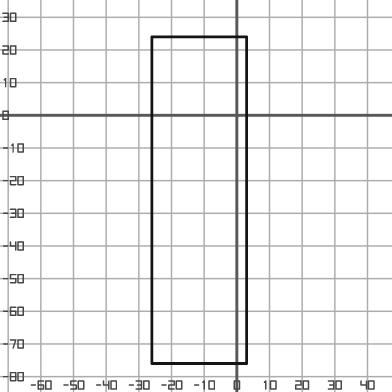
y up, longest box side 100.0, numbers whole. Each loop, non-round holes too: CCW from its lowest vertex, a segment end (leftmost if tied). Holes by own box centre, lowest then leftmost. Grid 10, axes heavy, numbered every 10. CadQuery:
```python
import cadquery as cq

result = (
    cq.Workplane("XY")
    .moveTo(-26.0, -76.0)
    .lineTo(3.0, -76.0)
    .lineTo(3.0, 24.0)
    .lineTo(-26.0, 24.0)
    .close()
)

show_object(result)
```